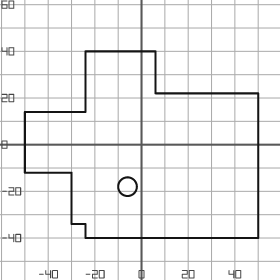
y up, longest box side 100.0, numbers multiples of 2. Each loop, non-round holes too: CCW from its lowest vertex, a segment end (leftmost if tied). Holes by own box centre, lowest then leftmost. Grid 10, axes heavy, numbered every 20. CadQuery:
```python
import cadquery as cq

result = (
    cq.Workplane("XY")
    .moveTo(-24.0, -40.0)
    .lineTo(50.0, -40.0)
    .lineTo(50.0, 22.0)
    .lineTo(6.0, 22.0)
    .lineTo(6.0, 40.0)
    .lineTo(-24.0, 40.0)
    .lineTo(-24.0, 14.0)
    .lineTo(-50.0, 14.0)
    .lineTo(-50.0, -12.0)
    .lineTo(-30.0, -12.0)
    .lineTo(-30.0, -34.0)
    .lineTo(-24.0, -34.0)
    .close()
    .moveTo(-6.0, -18.0)
    .circle(4.0)
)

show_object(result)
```